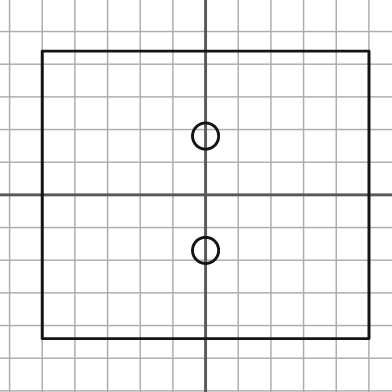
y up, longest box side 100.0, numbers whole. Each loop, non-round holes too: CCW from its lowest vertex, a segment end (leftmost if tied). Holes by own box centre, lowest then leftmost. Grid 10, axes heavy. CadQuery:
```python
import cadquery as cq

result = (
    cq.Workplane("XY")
    .moveTo(-50.0, -44.0)
    .lineTo(50.0, -44.0)
    .lineTo(50.0, 44.0)
    .lineTo(-50.0, 44.0)
    .close()
    .moveTo(0.0, -17.0)
    .circle(4.0)
    .moveTo(0.0, 18.0)
    .circle(4.0)
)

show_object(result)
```